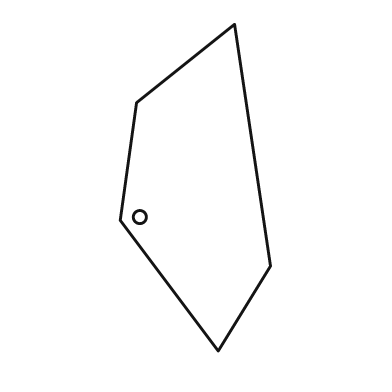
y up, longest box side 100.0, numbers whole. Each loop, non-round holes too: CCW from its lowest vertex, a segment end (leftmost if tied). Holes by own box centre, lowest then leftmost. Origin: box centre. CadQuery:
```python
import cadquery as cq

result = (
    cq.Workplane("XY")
    .moveTo(7.0, -50.0)
    .lineTo(23.0, -24.0)
    .lineTo(12.0, 50.0)
    .lineTo(-18.0, 26.0)
    .lineTo(-23.0, -10.0)
    .close()
    .moveTo(-17.0, -9.0)
    .circle(2.0)
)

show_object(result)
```